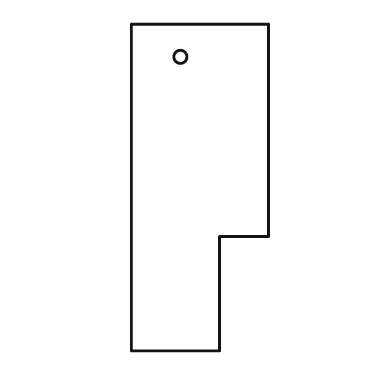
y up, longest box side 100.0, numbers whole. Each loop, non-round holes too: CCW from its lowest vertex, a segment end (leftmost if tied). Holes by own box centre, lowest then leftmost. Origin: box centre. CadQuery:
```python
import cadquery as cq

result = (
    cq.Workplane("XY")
    .moveTo(-21.0, -50.0)
    .lineTo(6.0, -50.0)
    .lineTo(6.0, -15.0)
    .lineTo(21.0, -15.0)
    .lineTo(21.0, 50.0)
    .lineTo(-21.0, 50.0)
    .close()
    .moveTo(-6.0, 40.0)
    .circle(2.0)
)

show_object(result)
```